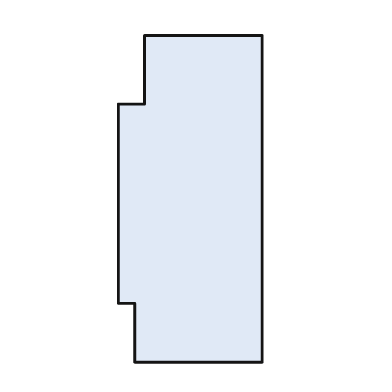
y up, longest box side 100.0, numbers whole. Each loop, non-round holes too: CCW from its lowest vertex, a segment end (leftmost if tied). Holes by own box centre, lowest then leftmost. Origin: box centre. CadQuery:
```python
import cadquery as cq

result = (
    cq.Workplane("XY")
    .moveTo(-17.0, -50.0)
    .lineTo(22.0, -50.0)
    .lineTo(22.0, 50.0)
    .lineTo(-14.0, 50.0)
    .lineTo(-14.0, 29.0)
    .lineTo(-22.0, 29.0)
    .lineTo(-22.0, -32.0)
    .lineTo(-17.0, -32.0)
    .close()
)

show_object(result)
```